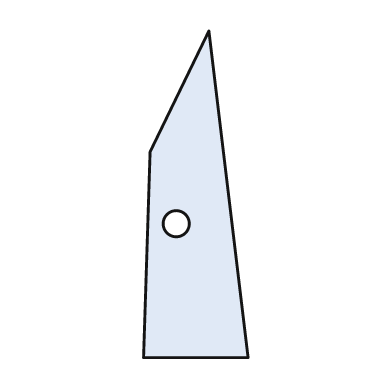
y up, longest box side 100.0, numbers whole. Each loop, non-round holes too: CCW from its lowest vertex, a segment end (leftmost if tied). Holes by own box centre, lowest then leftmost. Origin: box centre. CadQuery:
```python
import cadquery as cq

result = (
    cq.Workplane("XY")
    .moveTo(-16.0, -50.0)
    .lineTo(16.0, -50.0)
    .lineTo(4.0, 50.0)
    .lineTo(-14.0, 13.0)
    .close()
    .moveTo(-6.0, -9.0)
    .circle(4.0)
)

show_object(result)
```